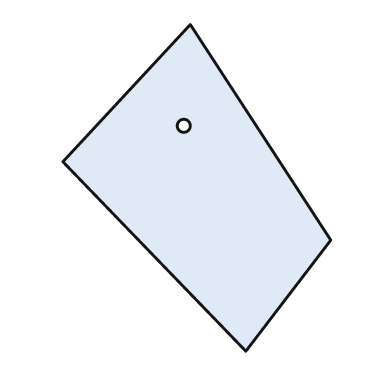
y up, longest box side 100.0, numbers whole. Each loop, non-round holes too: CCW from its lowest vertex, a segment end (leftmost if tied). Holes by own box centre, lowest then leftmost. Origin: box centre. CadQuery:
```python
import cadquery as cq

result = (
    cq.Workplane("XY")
    .moveTo(15.0, -50.0)
    .lineTo(41.0, -16.0)
    .lineTo(-2.0, 50.0)
    .lineTo(-41.0, 8.0)
    .close()
    .moveTo(-4.0, 19.0)
    .circle(2.0)
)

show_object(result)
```